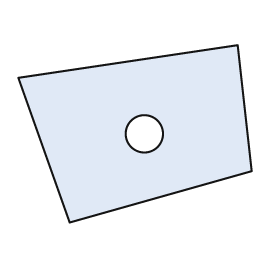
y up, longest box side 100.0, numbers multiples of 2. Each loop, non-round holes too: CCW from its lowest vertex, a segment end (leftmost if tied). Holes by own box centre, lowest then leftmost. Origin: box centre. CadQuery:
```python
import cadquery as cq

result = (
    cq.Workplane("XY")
    .moveTo(-28.0, -38.0)
    .lineTo(50.0, -16.0)
    .lineTo(44.0, 38.0)
    .lineTo(-50.0, 24.0)
    .close()
    .moveTo(4.0, 0.0)
    .circle(8.0)
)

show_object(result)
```